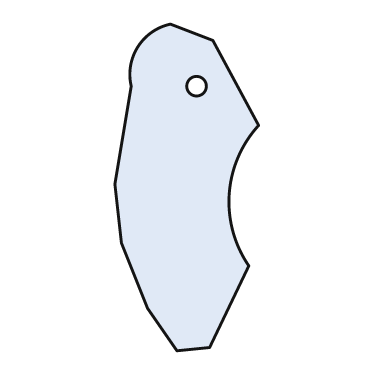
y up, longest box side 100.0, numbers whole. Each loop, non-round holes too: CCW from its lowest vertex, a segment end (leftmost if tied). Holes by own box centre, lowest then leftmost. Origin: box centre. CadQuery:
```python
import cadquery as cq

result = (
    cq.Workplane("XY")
    .moveTo(-3.0, -50.0)
    .lineTo(7.0, -49.0)
    .lineTo(19.0, -24.0)
    .threePointArc((13.0, -2.0), (22.0, 19.0))
    .lineTo(8.0, 45.0)
    .lineTo(-5.0, 50.0)
    .threePointArc((-15.0, 43.0), (-17.0, 31.0))
    .lineTo(-22.0, 1.0)
    .lineTo(-20.0, -17.0)
    .lineTo(-12.0, -37.0)
    .close()
    .moveTo(3.0, 31.0)
    .circle(3.0)
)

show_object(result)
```